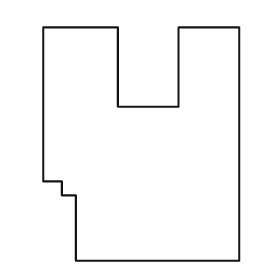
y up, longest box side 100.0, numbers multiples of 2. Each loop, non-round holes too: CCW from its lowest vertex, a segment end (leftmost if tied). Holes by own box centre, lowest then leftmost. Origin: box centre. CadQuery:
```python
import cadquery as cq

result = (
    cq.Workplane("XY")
    .moveTo(-28.0, -50.0)
    .lineTo(42.0, -50.0)
    .lineTo(42.0, 50.0)
    .lineTo(16.0, 50.0)
    .lineTo(16.0, 16.0)
    .lineTo(-10.0, 16.0)
    .lineTo(-10.0, 50.0)
    .lineTo(-42.0, 50.0)
    .lineTo(-42.0, -16.0)
    .lineTo(-34.0, -16.0)
    .lineTo(-34.0, -22.0)
    .lineTo(-28.0, -22.0)
    .close()
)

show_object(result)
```